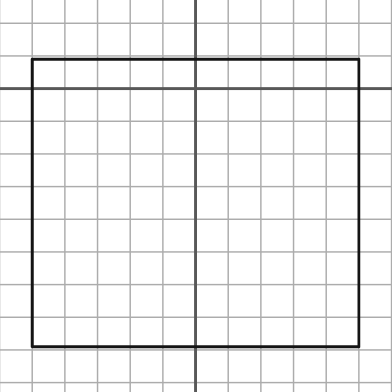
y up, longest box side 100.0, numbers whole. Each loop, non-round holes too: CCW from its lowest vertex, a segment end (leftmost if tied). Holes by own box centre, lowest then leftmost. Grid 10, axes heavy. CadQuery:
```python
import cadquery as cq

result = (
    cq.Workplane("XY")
    .moveTo(-50.0, -79.0)
    .lineTo(50.0, -79.0)
    .lineTo(50.0, 9.0)
    .lineTo(-50.0, 9.0)
    .close()
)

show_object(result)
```